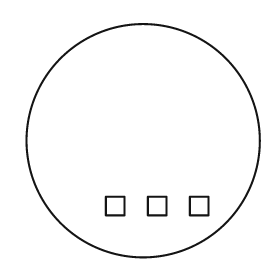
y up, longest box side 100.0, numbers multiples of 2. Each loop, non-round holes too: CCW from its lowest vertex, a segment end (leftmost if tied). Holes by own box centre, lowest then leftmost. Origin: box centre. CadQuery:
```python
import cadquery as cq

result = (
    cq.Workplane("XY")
    .moveTo(0.0, 0.0)
    .circle(50.0)
    .moveTo(-16.0, -32.0)
    .lineTo(-8.0, -32.0)
    .lineTo(-8.0, -24.0)
    .lineTo(-16.0, -24.0)
    .close()
    .moveTo(2.0, -32.0)
    .lineTo(10.0, -32.0)
    .lineTo(10.0, -24.0)
    .lineTo(2.0, -24.0)
    .close()
    .moveTo(20.0, -32.0)
    .lineTo(28.0, -32.0)
    .lineTo(28.0, -24.0)
    .lineTo(20.0, -24.0)
    .close()
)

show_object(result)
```